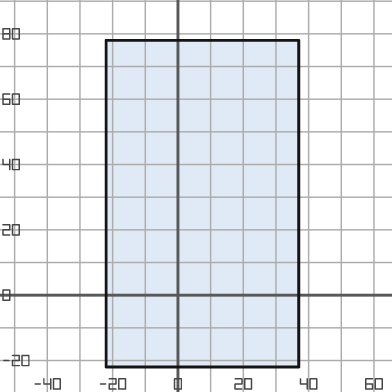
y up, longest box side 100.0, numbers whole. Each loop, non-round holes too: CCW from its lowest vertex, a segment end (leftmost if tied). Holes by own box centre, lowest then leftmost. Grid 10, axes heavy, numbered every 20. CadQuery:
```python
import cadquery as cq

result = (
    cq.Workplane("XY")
    .moveTo(-22.0, -22.0)
    .lineTo(37.0, -22.0)
    .lineTo(37.0, 78.0)
    .lineTo(-22.0, 78.0)
    .close()
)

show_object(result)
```